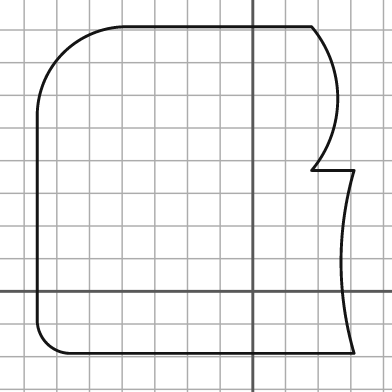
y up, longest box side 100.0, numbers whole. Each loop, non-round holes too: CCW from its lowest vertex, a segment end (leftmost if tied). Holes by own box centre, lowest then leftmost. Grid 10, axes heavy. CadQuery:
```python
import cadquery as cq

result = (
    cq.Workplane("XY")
    .moveTo(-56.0, -19.0)
    .lineTo(31.0, -19.0)
    .threePointArc((27.0, 9.0), (31.0, 37.0))
    .lineTo(18.0, 37.0)
    .threePointArc((26.0, 59.0), (18.0, 81.0))
    .lineTo(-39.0, 81.0)
    .threePointArc((-58.0, 73.0), (-66.0, 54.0))
    .lineTo(-66.0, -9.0)
    .threePointArc((-63.0, -16.0), (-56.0, -19.0))
    .close()
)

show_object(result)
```